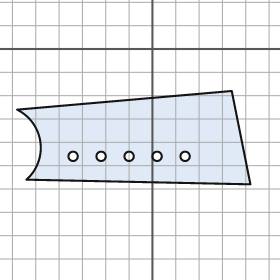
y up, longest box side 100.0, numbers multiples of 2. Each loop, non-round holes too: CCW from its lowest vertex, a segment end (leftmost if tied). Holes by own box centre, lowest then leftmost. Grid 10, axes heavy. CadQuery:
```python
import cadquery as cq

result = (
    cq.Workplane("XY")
    .moveTo(42.0, -58.0)
    .lineTo(34.0, -18.0)
    .lineTo(-58.0, -26.0)
    .threePointArc((-48.0, -40.0), (-54.0, -56.0))
    .close()
    .moveTo(-34.0, -46.0)
    .circle(2.0)
    .moveTo(-22.0, -46.0)
    .circle(2.0)
    .moveTo(-10.0, -46.0)
    .circle(2.0)
    .moveTo(2.0, -46.0)
    .circle(2.0)
    .moveTo(14.0, -46.0)
    .circle(2.0)
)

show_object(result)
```